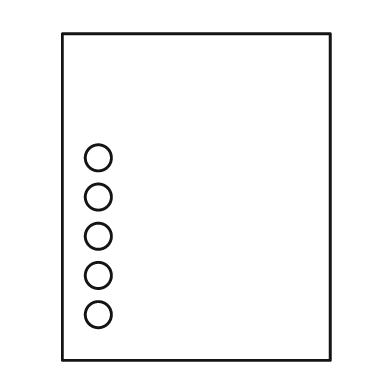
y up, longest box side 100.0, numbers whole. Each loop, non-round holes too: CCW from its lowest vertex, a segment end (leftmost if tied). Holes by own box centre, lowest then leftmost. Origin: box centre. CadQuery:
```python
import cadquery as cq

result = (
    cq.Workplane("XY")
    .moveTo(-41.0, -50.0)
    .lineTo(41.0, -50.0)
    .lineTo(41.0, 50.0)
    .lineTo(-41.0, 50.0)
    .close()
    .moveTo(-30.0, -36.0)
    .circle(4.0)
    .moveTo(-30.0, -24.0)
    .circle(4.0)
    .moveTo(-30.0, -12.0)
    .circle(4.0)
    .moveTo(-30.0, 0.0)
    .circle(4.0)
    .moveTo(-30.0, 12.0)
    .circle(4.0)
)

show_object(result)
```